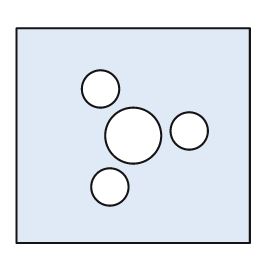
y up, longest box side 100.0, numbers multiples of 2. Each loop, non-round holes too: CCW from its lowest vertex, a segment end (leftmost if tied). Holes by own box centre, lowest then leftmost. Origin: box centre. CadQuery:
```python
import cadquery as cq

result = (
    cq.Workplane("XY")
    .moveTo(-50.0, -46.0)
    .lineTo(50.0, -46.0)
    .lineTo(50.0, 46.0)
    .lineTo(-50.0, 46.0)
    .close()
    .moveTo(-10.0, -22.0)
    .circle(8.0)
    .moveTo(0.0, 0.0)
    .circle(12.0)
    .moveTo(24.0, 2.0)
    .circle(8.0)
    .moveTo(-14.0, 20.0)
    .circle(8.0)
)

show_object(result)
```